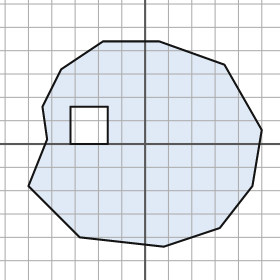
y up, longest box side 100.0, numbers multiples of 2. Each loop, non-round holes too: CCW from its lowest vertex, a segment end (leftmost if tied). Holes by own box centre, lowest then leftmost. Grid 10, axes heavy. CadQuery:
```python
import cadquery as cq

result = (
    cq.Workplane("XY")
    .moveTo(8.0, -44.0)
    .lineTo(32.0, -36.0)
    .lineTo(46.0, -18.0)
    .lineTo(50.0, 6.0)
    .lineTo(34.0, 34.0)
    .lineTo(6.0, 44.0)
    .lineTo(-18.0, 44.0)
    .lineTo(-36.0, 32.0)
    .lineTo(-44.0, 16.0)
    .lineTo(-42.0, 2.0)
    .lineTo(-50.0, -18.0)
    .lineTo(-28.0, -40.0)
    .close()
    .moveTo(-32.0, 0.0)
    .lineTo(-16.0, 0.0)
    .lineTo(-16.0, 16.0)
    .lineTo(-32.0, 16.0)
    .close()
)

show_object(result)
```